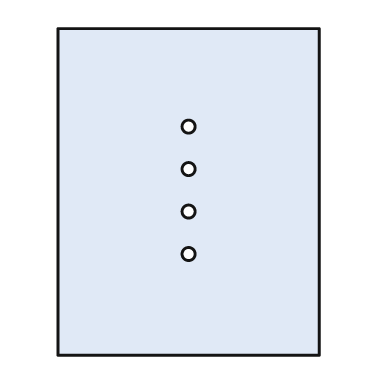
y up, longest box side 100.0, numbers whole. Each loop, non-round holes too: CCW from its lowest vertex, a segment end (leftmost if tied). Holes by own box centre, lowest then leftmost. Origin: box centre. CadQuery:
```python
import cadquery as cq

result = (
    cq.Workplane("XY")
    .moveTo(-40.0, -50.0)
    .lineTo(40.0, -50.0)
    .lineTo(40.0, 50.0)
    .lineTo(-40.0, 50.0)
    .close()
    .moveTo(0.0, -19.0)
    .circle(2.0)
    .moveTo(0.0, -6.0)
    .circle(2.0)
    .moveTo(0.0, 7.0)
    .circle(2.0)
    .moveTo(0.0, 20.0)
    .circle(2.0)
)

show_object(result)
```